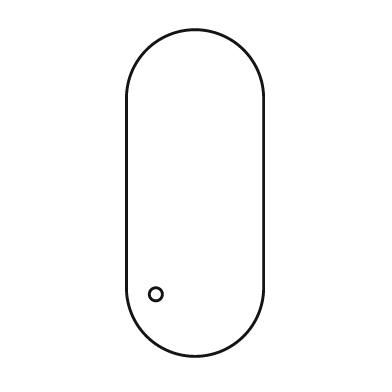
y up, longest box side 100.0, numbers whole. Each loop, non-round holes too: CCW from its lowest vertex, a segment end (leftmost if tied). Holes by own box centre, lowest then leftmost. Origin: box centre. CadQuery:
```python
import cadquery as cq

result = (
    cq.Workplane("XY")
    .moveTo(-21.0, -29.0)
    .threePointArc((0.0, -50.0), (21.0, -29.0))
    .lineTo(21.0, 29.0)
    .threePointArc((0.0, 50.0), (-21.0, 29.0))
    .close()
    .moveTo(-12.0, -31.0)
    .circle(2.0)
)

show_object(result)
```